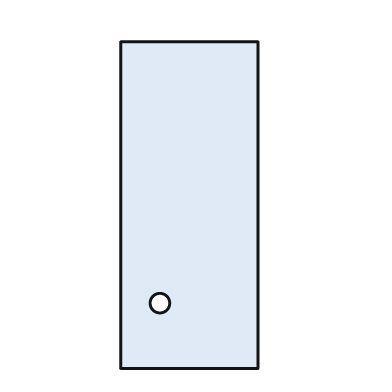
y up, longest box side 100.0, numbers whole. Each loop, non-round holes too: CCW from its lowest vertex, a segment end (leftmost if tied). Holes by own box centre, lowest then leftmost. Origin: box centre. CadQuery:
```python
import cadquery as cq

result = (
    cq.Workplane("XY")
    .moveTo(-21.0, -50.0)
    .lineTo(21.0, -50.0)
    .lineTo(21.0, 50.0)
    .lineTo(-21.0, 50.0)
    .close()
    .moveTo(-9.0, -30.0)
    .circle(3.0)
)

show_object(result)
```